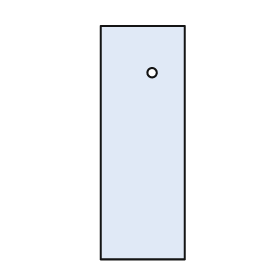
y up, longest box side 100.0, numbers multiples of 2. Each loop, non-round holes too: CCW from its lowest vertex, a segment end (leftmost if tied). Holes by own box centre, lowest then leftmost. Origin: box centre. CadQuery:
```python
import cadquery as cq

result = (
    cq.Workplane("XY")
    .moveTo(-18.0, -50.0)
    .lineTo(18.0, -50.0)
    .lineTo(18.0, 50.0)
    .lineTo(-18.0, 50.0)
    .close()
    .moveTo(4.0, 30.0)
    .circle(2.0)
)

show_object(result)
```